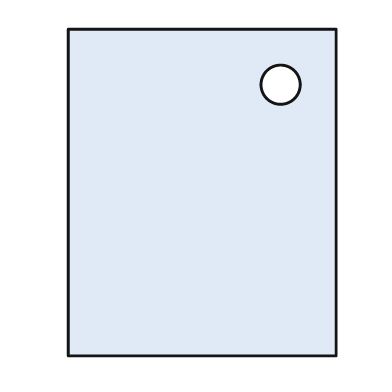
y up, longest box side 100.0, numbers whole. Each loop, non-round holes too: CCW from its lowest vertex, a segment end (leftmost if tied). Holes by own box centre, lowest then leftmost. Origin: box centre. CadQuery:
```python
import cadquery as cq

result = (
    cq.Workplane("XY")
    .moveTo(-41.0, -50.0)
    .lineTo(41.0, -50.0)
    .lineTo(41.0, 50.0)
    .lineTo(-41.0, 50.0)
    .close()
    .moveTo(24.0, 33.0)
    .circle(6.0)
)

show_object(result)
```